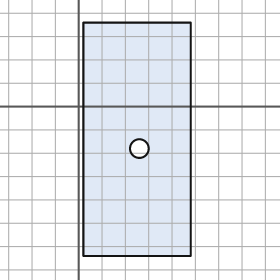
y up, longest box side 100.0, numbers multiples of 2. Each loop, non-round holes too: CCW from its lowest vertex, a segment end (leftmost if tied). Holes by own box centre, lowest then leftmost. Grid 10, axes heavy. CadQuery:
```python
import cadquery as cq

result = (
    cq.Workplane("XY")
    .moveTo(2.0, -64.0)
    .lineTo(48.0, -64.0)
    .lineTo(48.0, 36.0)
    .lineTo(2.0, 36.0)
    .close()
    .moveTo(26.0, -18.0)
    .circle(4.0)
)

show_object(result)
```